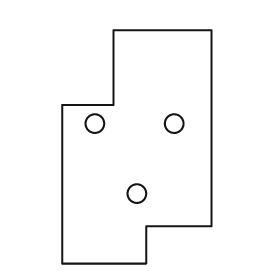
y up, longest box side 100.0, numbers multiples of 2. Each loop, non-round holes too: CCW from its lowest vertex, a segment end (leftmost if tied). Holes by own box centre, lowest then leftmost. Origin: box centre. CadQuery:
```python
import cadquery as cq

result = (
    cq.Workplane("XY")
    .moveTo(-32.0, -50.0)
    .lineTo(4.0, -50.0)
    .lineTo(4.0, -34.0)
    .lineTo(32.0, -34.0)
    .lineTo(32.0, 50.0)
    .lineTo(-10.0, 50.0)
    .lineTo(-10.0, 18.0)
    .lineTo(-32.0, 18.0)
    .close()
    .moveTo(0.0, -20.0)
    .circle(4.0)
    .moveTo(-18.0, 10.0)
    .circle(4.0)
    .moveTo(16.0, 10.0)
    .circle(4.0)
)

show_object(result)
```